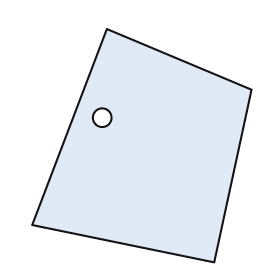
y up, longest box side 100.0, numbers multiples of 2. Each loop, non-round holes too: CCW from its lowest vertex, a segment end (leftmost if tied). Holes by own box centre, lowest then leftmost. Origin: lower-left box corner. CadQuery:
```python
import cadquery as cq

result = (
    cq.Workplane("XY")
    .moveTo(78.0, 0.0)
    .lineTo(94.0, 74.0)
    .lineTo(32.0, 100.0)
    .lineTo(0.0, 16.0)
    .close()
    .moveTo(30.0, 62.0)
    .circle(4.0)
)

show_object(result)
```